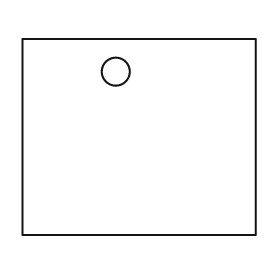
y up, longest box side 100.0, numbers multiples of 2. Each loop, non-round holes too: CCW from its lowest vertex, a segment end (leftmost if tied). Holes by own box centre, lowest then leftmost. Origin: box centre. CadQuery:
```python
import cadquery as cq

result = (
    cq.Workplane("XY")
    .moveTo(-50.0, -42.0)
    .lineTo(50.0, -42.0)
    .lineTo(50.0, 42.0)
    .lineTo(-50.0, 42.0)
    .close()
    .moveTo(-10.0, 28.0)
    .circle(6.0)
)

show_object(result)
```